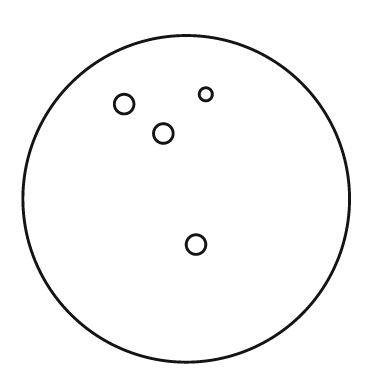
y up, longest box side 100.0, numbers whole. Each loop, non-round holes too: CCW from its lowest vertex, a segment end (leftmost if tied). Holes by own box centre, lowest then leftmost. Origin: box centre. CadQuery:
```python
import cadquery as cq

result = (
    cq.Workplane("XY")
    .moveTo(0.0, 0.0)
    .circle(50.0)
    .moveTo(3.0, -14.0)
    .circle(3.0)
    .moveTo(-7.0, 20.0)
    .circle(3.0)
    .moveTo(-19.0, 29.0)
    .circle(3.0)
    .moveTo(6.0, 32.0)
    .circle(2.0)
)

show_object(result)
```